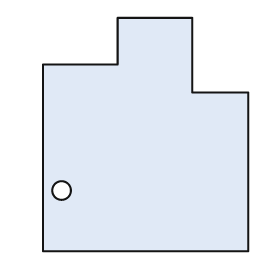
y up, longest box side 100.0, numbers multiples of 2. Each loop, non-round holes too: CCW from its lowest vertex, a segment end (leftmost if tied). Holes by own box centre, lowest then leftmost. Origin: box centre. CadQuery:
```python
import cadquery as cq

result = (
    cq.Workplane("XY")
    .moveTo(-44.0, -50.0)
    .lineTo(44.0, -50.0)
    .lineTo(44.0, 18.0)
    .lineTo(20.0, 18.0)
    .lineTo(20.0, 50.0)
    .lineTo(-12.0, 50.0)
    .lineTo(-12.0, 30.0)
    .lineTo(-44.0, 30.0)
    .close()
    .moveTo(-36.0, -24.0)
    .circle(4.0)
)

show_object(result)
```